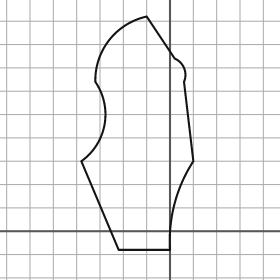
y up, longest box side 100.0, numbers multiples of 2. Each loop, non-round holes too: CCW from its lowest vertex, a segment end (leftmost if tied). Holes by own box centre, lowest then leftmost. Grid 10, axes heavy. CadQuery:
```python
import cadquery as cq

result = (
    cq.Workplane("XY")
    .moveTo(-22.0, -8.0)
    .lineTo(0.0, -8.0)
    .threePointArc((2.0, 12.0), (10.0, 30.0))
    .lineTo(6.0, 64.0)
    .threePointArc((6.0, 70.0), (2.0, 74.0))
    .lineTo(-10.0, 92.0)
    .threePointArc((-26.0, 82.0), (-32.0, 64.0))
    .threePointArc((-28.0, 46.0), (-38.0, 30.0))
    .close()
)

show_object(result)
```